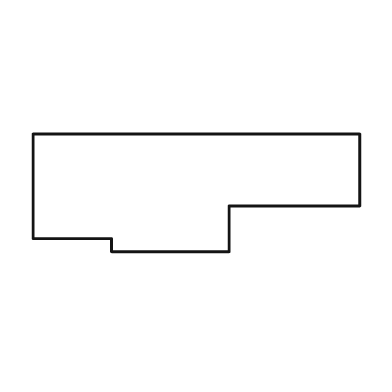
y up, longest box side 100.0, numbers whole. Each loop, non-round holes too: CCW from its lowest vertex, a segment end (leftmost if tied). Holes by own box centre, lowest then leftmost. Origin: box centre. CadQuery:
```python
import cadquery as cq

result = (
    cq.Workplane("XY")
    .moveTo(-26.0, -18.0)
    .lineTo(10.0, -18.0)
    .lineTo(10.0, -4.0)
    .lineTo(50.0, -4.0)
    .lineTo(50.0, 18.0)
    .lineTo(-50.0, 18.0)
    .lineTo(-50.0, -14.0)
    .lineTo(-26.0, -14.0)
    .close()
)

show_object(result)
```